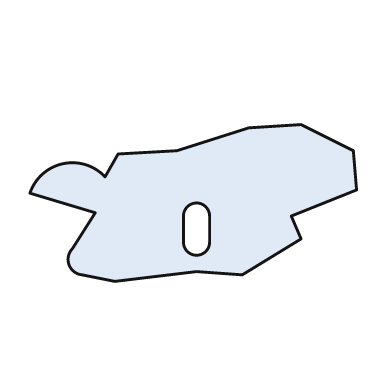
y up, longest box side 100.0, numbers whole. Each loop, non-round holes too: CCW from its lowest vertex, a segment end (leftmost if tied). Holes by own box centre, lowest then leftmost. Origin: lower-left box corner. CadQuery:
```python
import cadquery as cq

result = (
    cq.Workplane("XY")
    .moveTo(26.0, 0.0)
    .lineTo(51.0, 3.0)
    .lineTo(65.0, 2.0)
    .lineTo(83.0, 13.0)
    .lineTo(80.0, 20.0)
    .lineTo(100.0, 28.0)
    .lineTo(99.0, 40.0)
    .lineTo(83.0, 48.0)
    .lineTo(67.0, 47.0)
    .lineTo(45.0, 40.0)
    .lineTo(27.0, 39.0)
    .lineTo(23.0, 32.0)
    .threePointArc((10.0, 36.0), (0.0, 27.0))
    .lineTo(20.0, 21.0)
    .lineTo(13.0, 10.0)
    .threePointArc((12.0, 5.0), (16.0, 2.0))
    .close()
    .moveTo(47.0, 12.0)
    .threePointArc((51.0, 8.0), (55.0, 12.0))
    .lineTo(55.0, 20.0)
    .threePointArc((51.0, 24.0), (47.0, 20.0))
    .close()
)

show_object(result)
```